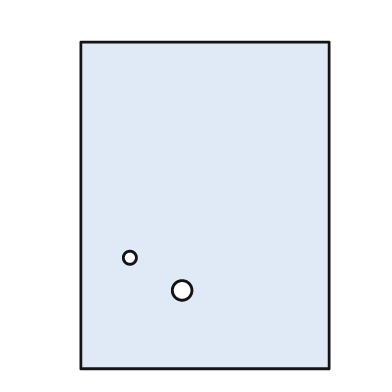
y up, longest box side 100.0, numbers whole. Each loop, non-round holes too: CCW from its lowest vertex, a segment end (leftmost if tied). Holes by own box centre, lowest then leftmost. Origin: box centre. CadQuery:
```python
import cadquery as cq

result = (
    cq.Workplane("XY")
    .moveTo(-38.0, -50.0)
    .lineTo(38.0, -50.0)
    .lineTo(38.0, 50.0)
    .lineTo(-38.0, 50.0)
    .close()
    .moveTo(-7.0, -26.0)
    .circle(3.0)
    .moveTo(-23.0, -16.0)
    .circle(2.0)
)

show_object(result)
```